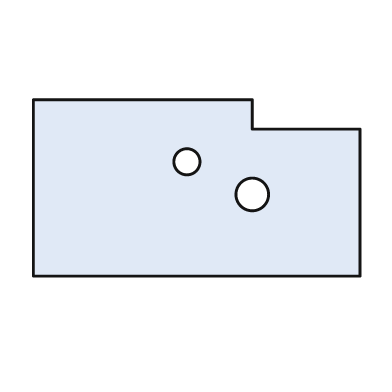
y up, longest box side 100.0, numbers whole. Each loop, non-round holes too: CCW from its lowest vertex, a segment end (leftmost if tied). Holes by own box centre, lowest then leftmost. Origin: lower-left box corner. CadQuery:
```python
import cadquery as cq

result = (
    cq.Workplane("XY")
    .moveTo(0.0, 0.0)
    .lineTo(100.0, 0.0)
    .lineTo(100.0, 45.0)
    .lineTo(67.0, 45.0)
    .lineTo(67.0, 54.0)
    .lineTo(0.0, 54.0)
    .close()
    .moveTo(67.0, 25.0)
    .circle(5.0)
    .moveTo(47.0, 35.0)
    .circle(4.0)
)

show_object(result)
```